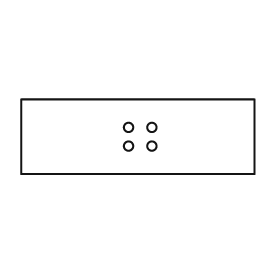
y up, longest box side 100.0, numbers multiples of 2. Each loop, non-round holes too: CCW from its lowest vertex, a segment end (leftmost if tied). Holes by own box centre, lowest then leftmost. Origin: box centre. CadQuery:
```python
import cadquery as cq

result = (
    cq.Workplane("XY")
    .moveTo(-50.0, -16.0)
    .lineTo(50.0, -16.0)
    .lineTo(50.0, 16.0)
    .lineTo(-50.0, 16.0)
    .close()
    .moveTo(-4.0, -4.0)
    .circle(2.0)
    .moveTo(6.0, -4.0)
    .circle(2.0)
    .moveTo(-4.0, 4.0)
    .circle(2.0)
    .moveTo(6.0, 4.0)
    .circle(2.0)
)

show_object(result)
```